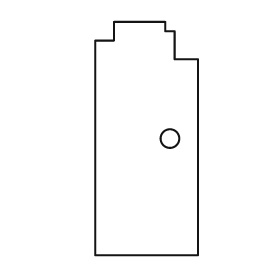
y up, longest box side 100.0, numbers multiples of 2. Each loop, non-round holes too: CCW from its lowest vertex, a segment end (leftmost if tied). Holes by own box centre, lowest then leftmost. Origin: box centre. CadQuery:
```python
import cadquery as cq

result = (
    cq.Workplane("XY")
    .moveTo(-22.0, -50.0)
    .lineTo(22.0, -50.0)
    .lineTo(22.0, 34.0)
    .lineTo(12.0, 34.0)
    .lineTo(12.0, 46.0)
    .lineTo(8.0, 46.0)
    .lineTo(8.0, 50.0)
    .lineTo(-14.0, 50.0)
    .lineTo(-14.0, 42.0)
    .lineTo(-22.0, 42.0)
    .close()
    .moveTo(10.0, 0.0)
    .circle(4.0)
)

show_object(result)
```